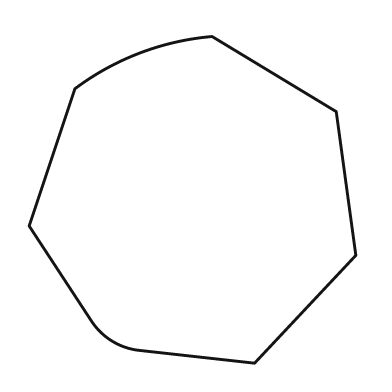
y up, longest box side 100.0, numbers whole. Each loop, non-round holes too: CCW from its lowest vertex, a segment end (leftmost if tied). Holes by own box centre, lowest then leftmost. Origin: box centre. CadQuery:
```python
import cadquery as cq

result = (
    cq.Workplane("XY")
    .moveTo(19.0, -50.0)
    .lineTo(50.0, -17.0)
    .lineTo(44.0, 27.0)
    .lineTo(6.0, 50.0)
    .threePointArc((-16.0, 45.0), (-36.0, 34.0))
    .lineTo(-50.0, -8.0)
    .lineTo(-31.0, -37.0)
    .threePointArc((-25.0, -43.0), (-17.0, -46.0))
    .close()
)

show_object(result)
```